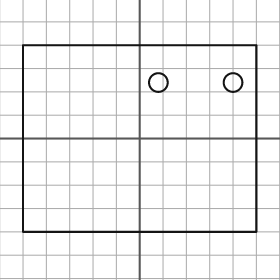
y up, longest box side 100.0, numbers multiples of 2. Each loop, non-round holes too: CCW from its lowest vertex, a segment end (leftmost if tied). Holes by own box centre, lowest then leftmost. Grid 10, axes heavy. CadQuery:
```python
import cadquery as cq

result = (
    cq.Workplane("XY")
    .moveTo(-50.0, -40.0)
    .lineTo(50.0, -40.0)
    .lineTo(50.0, 40.0)
    .lineTo(-50.0, 40.0)
    .close()
    .moveTo(8.0, 24.0)
    .circle(4.0)
    .moveTo(40.0, 24.0)
    .circle(4.0)
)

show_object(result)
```